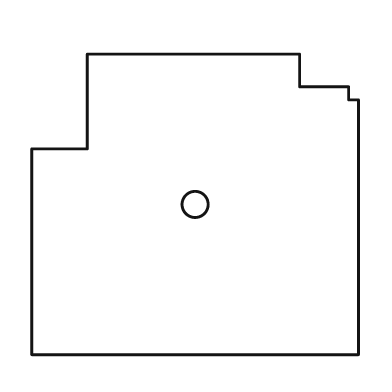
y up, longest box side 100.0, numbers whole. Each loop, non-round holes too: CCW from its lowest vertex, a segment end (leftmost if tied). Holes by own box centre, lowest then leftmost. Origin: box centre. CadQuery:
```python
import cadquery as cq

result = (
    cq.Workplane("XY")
    .moveTo(-50.0, -46.0)
    .lineTo(50.0, -46.0)
    .lineTo(50.0, 32.0)
    .lineTo(47.0, 32.0)
    .lineTo(47.0, 36.0)
    .lineTo(32.0, 36.0)
    .lineTo(32.0, 46.0)
    .lineTo(-33.0, 46.0)
    .lineTo(-33.0, 17.0)
    .lineTo(-50.0, 17.0)
    .close()
    .moveTo(0.0, 0.0)
    .circle(4.0)
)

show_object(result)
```